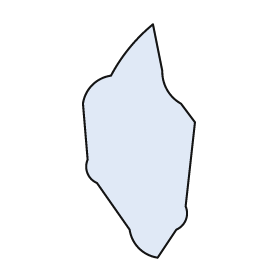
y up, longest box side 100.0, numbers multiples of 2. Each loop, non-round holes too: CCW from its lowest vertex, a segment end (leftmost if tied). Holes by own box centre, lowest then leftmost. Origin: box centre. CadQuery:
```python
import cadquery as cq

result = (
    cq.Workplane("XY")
    .moveTo(8.0, -50.0)
    .lineTo(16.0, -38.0)
    .threePointArc((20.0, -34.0), (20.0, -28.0))
    .lineTo(24.0, 8.0)
    .lineTo(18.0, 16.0)
    .threePointArc((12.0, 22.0), (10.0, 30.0))
    .lineTo(6.0, 50.0)
    .threePointArc((-4.0, 40.0), (-12.0, 28.0))
    .threePointArc((-20.0, 24.0), (-24.0, 16.0))
    .lineTo(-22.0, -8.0)
    .threePointArc((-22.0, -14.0), (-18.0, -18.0))
    .lineTo(-4.0, -38.0)
    .threePointArc((0.0, -46.0), (8.0, -50.0))
    .close()
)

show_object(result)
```